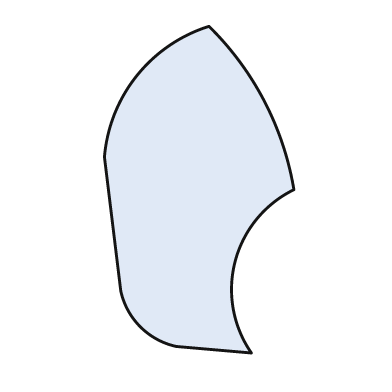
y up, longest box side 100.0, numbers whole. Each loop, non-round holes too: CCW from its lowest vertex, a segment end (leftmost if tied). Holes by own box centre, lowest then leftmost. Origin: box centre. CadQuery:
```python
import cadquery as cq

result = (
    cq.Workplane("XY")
    .moveTo(16.0, -50.0)
    .threePointArc((11.0, -22.0), (29.0, 0.0))
    .threePointArc((20.0, 27.0), (3.0, 50.0))
    .threePointArc((-19.0, 35.0), (-29.0, 10.0))
    .lineTo(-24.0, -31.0)
    .threePointArc((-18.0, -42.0), (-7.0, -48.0))
    .close()
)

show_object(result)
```